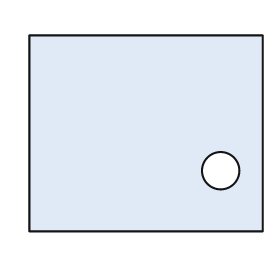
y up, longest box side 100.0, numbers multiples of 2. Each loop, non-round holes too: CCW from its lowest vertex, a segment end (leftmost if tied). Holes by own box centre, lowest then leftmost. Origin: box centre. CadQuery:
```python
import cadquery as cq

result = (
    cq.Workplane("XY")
    .moveTo(-50.0, -42.0)
    .lineTo(50.0, -42.0)
    .lineTo(50.0, 42.0)
    .lineTo(-50.0, 42.0)
    .close()
    .moveTo(32.0, -16.0)
    .circle(8.0)
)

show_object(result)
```